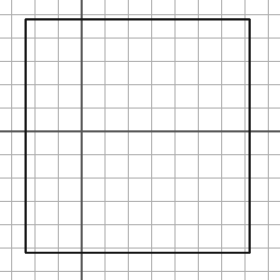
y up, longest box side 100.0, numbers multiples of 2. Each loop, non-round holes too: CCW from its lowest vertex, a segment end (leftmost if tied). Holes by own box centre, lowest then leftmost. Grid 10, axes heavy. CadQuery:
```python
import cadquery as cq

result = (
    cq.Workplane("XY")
    .moveTo(-24.0, -52.0)
    .lineTo(72.0, -52.0)
    .lineTo(72.0, 48.0)
    .lineTo(-24.0, 48.0)
    .close()
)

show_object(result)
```